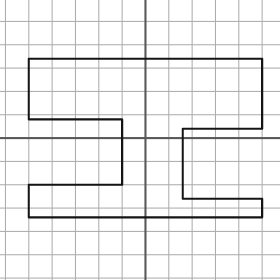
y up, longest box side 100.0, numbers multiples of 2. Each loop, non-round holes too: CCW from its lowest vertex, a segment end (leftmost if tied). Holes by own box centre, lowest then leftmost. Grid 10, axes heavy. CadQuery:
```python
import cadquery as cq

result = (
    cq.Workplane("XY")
    .moveTo(-50.0, -34.0)
    .lineTo(50.0, -34.0)
    .lineTo(50.0, -26.0)
    .lineTo(16.0, -26.0)
    .lineTo(16.0, 4.0)
    .lineTo(50.0, 4.0)
    .lineTo(50.0, 34.0)
    .lineTo(-50.0, 34.0)
    .lineTo(-50.0, 8.0)
    .lineTo(-10.0, 8.0)
    .lineTo(-10.0, -20.0)
    .lineTo(-50.0, -20.0)
    .close()
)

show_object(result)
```